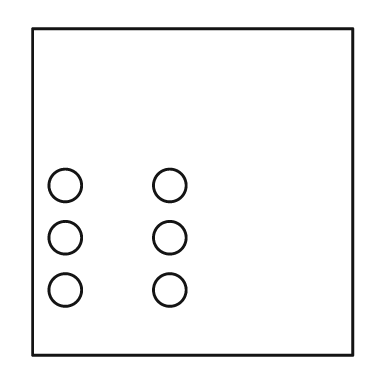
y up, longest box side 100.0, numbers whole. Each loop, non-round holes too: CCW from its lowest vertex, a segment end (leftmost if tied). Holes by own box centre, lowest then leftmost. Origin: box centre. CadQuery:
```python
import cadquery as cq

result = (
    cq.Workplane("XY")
    .moveTo(-49.0, -50.0)
    .lineTo(49.0, -50.0)
    .lineTo(49.0, 50.0)
    .lineTo(-49.0, 50.0)
    .close()
    .moveTo(-39.0, -30.0)
    .circle(5.0)
    .moveTo(-7.0, -30.0)
    .circle(5.0)
    .moveTo(-39.0, -14.0)
    .circle(5.0)
    .moveTo(-7.0, -14.0)
    .circle(5.0)
    .moveTo(-39.0, 2.0)
    .circle(5.0)
    .moveTo(-7.0, 2.0)
    .circle(5.0)
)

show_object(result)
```